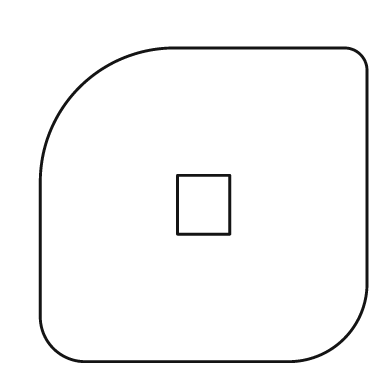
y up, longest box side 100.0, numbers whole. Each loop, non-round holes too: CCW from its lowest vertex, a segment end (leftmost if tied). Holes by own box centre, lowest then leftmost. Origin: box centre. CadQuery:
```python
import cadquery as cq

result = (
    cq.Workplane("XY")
    .moveTo(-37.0, -48.0)
    .lineTo(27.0, -48.0)
    .threePointArc((43.0, -41.0), (50.0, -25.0))
    .lineTo(50.0, 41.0)
    .threePointArc((48.0, 46.0), (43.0, 48.0))
    .lineTo(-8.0, 48.0)
    .threePointArc((-38.0, 36.0), (-50.0, 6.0))
    .lineTo(-50.0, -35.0)
    .threePointArc((-46.0, -44.0), (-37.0, -48.0))
    .close()
    .moveTo(-8.0, -9.0)
    .lineTo(8.0, -9.0)
    .lineTo(8.0, 9.0)
    .lineTo(-8.0, 9.0)
    .close()
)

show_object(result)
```